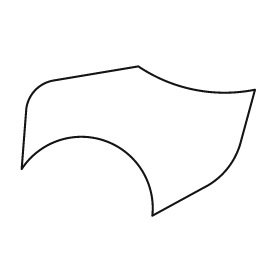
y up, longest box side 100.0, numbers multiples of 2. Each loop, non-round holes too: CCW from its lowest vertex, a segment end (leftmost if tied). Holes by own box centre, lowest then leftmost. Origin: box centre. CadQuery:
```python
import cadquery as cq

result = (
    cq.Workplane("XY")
    .moveTo(6.0, -32.0)
    .lineTo(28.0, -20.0)
    .threePointArc((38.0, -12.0), (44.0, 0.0))
    .lineTo(50.0, 22.0)
    .threePointArc((24.0, 22.0), (0.0, 32.0))
    .lineTo(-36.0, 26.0)
    .threePointArc((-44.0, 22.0), (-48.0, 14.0))
    .lineTo(-50.0, -12.0)
    .threePointArc((-14.0, 0.0), (6.0, -32.0))
    .close()
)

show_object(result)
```